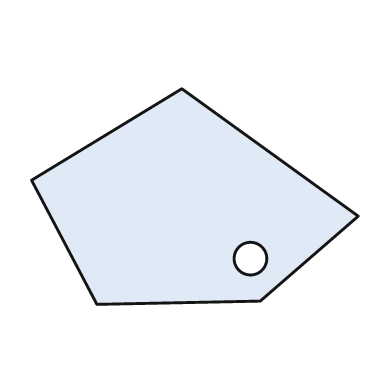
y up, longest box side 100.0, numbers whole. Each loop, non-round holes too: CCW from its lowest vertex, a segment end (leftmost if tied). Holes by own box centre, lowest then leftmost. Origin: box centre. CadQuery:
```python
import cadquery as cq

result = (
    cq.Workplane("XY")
    .moveTo(-30.0, -33.0)
    .lineTo(20.0, -32.0)
    .lineTo(50.0, -6.0)
    .lineTo(-4.0, 33.0)
    .lineTo(-50.0, 5.0)
    .close()
    .moveTo(17.0, -19.0)
    .circle(5.0)
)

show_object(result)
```